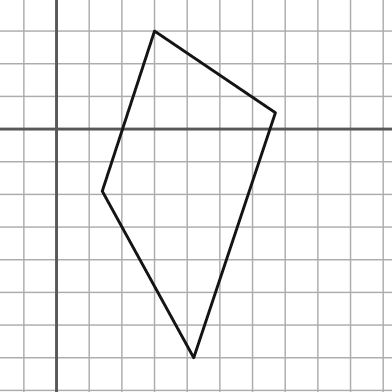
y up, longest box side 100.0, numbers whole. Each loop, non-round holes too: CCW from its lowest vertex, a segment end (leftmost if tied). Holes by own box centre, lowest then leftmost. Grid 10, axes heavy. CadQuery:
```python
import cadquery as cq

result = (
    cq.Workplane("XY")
    .moveTo(42.0, -70.0)
    .lineTo(67.0, 5.0)
    .lineTo(30.0, 30.0)
    .lineTo(14.0, -19.0)
    .close()
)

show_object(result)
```